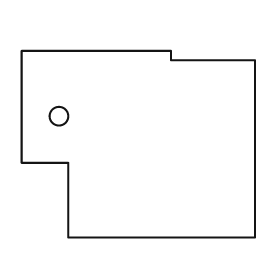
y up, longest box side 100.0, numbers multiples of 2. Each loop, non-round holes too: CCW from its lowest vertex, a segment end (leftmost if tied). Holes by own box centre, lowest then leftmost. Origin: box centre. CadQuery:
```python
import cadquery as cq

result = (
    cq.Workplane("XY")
    .moveTo(-30.0, -40.0)
    .lineTo(50.0, -40.0)
    .lineTo(50.0, 36.0)
    .lineTo(14.0, 36.0)
    .lineTo(14.0, 40.0)
    .lineTo(-50.0, 40.0)
    .lineTo(-50.0, -8.0)
    .lineTo(-30.0, -8.0)
    .close()
    .moveTo(-34.0, 12.0)
    .circle(4.0)
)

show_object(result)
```